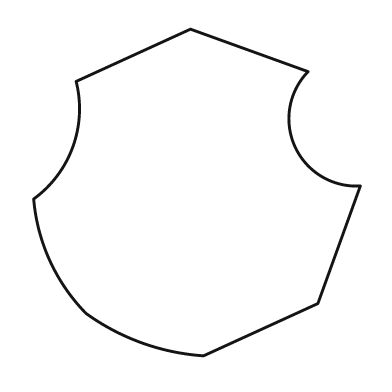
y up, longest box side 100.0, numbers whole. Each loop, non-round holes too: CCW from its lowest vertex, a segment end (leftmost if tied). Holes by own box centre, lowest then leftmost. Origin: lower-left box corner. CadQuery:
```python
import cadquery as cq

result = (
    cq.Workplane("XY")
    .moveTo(52.0, 0.0)
    .lineTo(87.0, 16.0)
    .lineTo(100.0, 52.0)
    .threePointArc((80.0, 64.0), (84.0, 87.0))
    .lineTo(48.0, 100.0)
    .lineTo(13.0, 84.0)
    .threePointArc((12.0, 64.0), (0.0, 48.0))
    .threePointArc((5.0, 29.0), (16.0, 13.0))
    .threePointArc((33.0, 4.0), (52.0, 0.0))
    .close()
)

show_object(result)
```